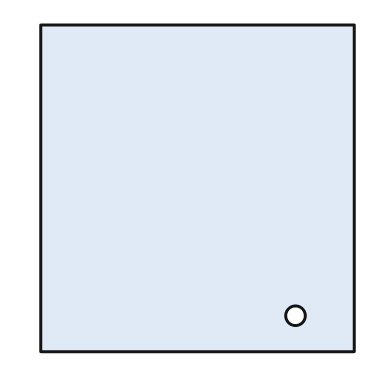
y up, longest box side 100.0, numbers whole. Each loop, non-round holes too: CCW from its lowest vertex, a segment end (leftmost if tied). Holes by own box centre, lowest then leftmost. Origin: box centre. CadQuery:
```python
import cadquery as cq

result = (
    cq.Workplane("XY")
    .moveTo(-48.0, -50.0)
    .lineTo(48.0, -50.0)
    .lineTo(48.0, 50.0)
    .lineTo(-48.0, 50.0)
    .close()
    .moveTo(30.0, -39.0)
    .circle(3.0)
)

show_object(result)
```